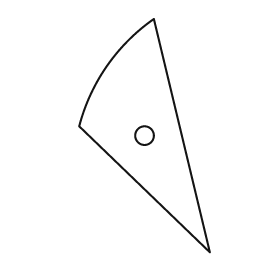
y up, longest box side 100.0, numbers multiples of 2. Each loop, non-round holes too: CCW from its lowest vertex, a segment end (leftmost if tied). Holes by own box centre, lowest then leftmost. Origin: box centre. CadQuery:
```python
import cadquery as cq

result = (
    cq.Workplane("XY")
    .moveTo(28.0, -50.0)
    .lineTo(4.0, 50.0)
    .threePointArc((-16.0, 30.0), (-28.0, 4.0))
    .close()
    .moveTo(0.0, 0.0)
    .circle(4.0)
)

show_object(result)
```